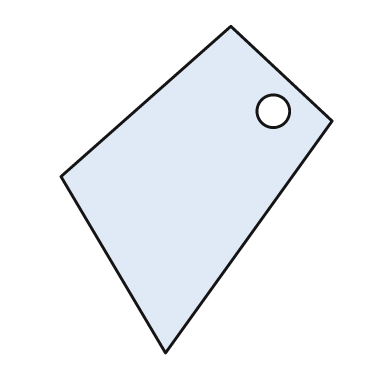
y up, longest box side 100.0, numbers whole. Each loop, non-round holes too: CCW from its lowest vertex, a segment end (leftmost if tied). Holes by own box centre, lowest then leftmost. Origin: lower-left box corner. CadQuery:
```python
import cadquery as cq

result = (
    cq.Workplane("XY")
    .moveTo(32.0, 0.0)
    .lineTo(83.0, 71.0)
    .lineTo(52.0, 100.0)
    .lineTo(0.0, 54.0)
    .close()
    .moveTo(65.0, 74.0)
    .circle(5.0)
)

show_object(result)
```